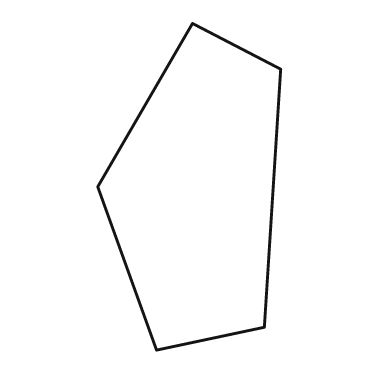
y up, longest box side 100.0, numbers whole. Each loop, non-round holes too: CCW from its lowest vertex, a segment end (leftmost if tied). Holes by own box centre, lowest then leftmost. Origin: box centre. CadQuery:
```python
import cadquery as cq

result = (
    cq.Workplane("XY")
    .moveTo(-10.0, -50.0)
    .lineTo(23.0, -43.0)
    .lineTo(28.0, 36.0)
    .lineTo(1.0, 50.0)
    .lineTo(-28.0, 0.0)
    .close()
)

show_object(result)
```